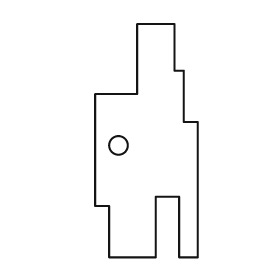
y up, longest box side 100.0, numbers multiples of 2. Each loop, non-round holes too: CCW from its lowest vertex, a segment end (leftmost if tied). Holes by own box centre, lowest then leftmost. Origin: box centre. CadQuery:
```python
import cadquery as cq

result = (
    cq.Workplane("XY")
    .moveTo(-16.0, -50.0)
    .lineTo(4.0, -50.0)
    .lineTo(4.0, -24.0)
    .lineTo(14.0, -24.0)
    .lineTo(14.0, -50.0)
    .lineTo(22.0, -50.0)
    .lineTo(22.0, 8.0)
    .lineTo(16.0, 8.0)
    .lineTo(16.0, 30.0)
    .lineTo(12.0, 30.0)
    .lineTo(12.0, 50.0)
    .lineTo(-4.0, 50.0)
    .lineTo(-4.0, 20.0)
    .lineTo(-22.0, 20.0)
    .lineTo(-22.0, -28.0)
    .lineTo(-16.0, -28.0)
    .close()
    .moveTo(-12.0, -2.0)
    .circle(4.0)
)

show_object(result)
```